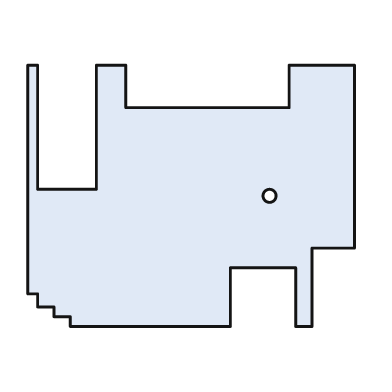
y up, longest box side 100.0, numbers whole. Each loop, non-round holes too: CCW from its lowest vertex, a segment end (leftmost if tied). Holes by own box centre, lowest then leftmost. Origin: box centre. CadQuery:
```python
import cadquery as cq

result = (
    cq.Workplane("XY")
    .moveTo(-37.0, -40.0)
    .lineTo(12.0, -40.0)
    .lineTo(12.0, -22.0)
    .lineTo(32.0, -22.0)
    .lineTo(32.0, -40.0)
    .lineTo(37.0, -40.0)
    .lineTo(37.0, -16.0)
    .lineTo(50.0, -16.0)
    .lineTo(50.0, 40.0)
    .lineTo(30.0, 40.0)
    .lineTo(30.0, 27.0)
    .lineTo(-20.0, 27.0)
    .lineTo(-20.0, 40.0)
    .lineTo(-29.0, 40.0)
    .lineTo(-29.0, 2.0)
    .lineTo(-47.0, 2.0)
    .lineTo(-47.0, 40.0)
    .lineTo(-50.0, 40.0)
    .lineTo(-50.0, -30.0)
    .lineTo(-47.0, -30.0)
    .lineTo(-47.0, -34.0)
    .lineTo(-42.0, -34.0)
    .lineTo(-42.0, -37.0)
    .lineTo(-37.0, -37.0)
    .close()
    .moveTo(24.0, 0.0)
    .circle(2.0)
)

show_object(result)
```